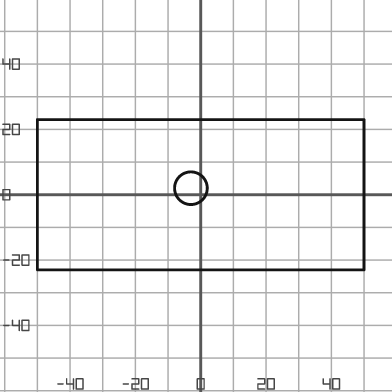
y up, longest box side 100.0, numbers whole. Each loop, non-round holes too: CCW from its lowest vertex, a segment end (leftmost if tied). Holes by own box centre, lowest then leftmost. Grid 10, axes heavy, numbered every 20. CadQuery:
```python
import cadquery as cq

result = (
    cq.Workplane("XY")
    .moveTo(-50.0, -23.0)
    .lineTo(50.0, -23.0)
    .lineTo(50.0, 23.0)
    .lineTo(-50.0, 23.0)
    .close()
    .moveTo(-3.0, 2.0)
    .circle(5.0)
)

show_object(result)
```